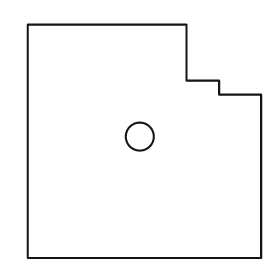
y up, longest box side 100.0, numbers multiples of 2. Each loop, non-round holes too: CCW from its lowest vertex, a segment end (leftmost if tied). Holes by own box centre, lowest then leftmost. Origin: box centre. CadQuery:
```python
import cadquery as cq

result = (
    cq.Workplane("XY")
    .moveTo(-50.0, -50.0)
    .lineTo(50.0, -50.0)
    .lineTo(50.0, 20.0)
    .lineTo(32.0, 20.0)
    .lineTo(32.0, 26.0)
    .lineTo(18.0, 26.0)
    .lineTo(18.0, 50.0)
    .lineTo(-50.0, 50.0)
    .close()
    .moveTo(-2.0, 2.0)
    .circle(6.0)
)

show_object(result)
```